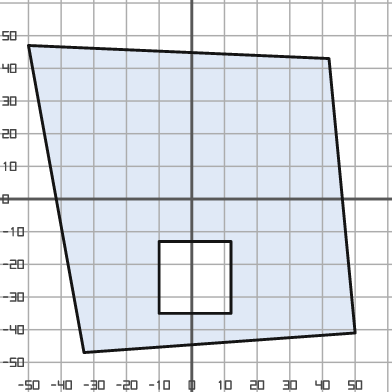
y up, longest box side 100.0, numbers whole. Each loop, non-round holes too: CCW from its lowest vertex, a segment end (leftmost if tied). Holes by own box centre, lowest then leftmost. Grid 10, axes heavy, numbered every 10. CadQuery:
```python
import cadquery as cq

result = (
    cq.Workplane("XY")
    .moveTo(-33.0, -47.0)
    .lineTo(50.0, -41.0)
    .lineTo(42.0, 43.0)
    .lineTo(-50.0, 47.0)
    .close()
    .moveTo(-10.0, -35.0)
    .lineTo(12.0, -35.0)
    .lineTo(12.0, -13.0)
    .lineTo(-10.0, -13.0)
    .close()
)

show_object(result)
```